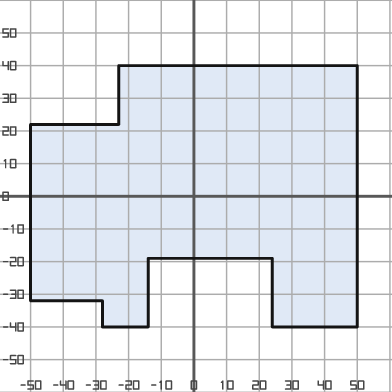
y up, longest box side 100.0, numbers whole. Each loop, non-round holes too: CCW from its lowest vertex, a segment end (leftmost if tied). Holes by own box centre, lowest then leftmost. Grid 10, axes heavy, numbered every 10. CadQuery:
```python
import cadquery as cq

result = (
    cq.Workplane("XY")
    .moveTo(-28.0, -40.0)
    .lineTo(-14.0, -40.0)
    .lineTo(-14.0, -19.0)
    .lineTo(24.0, -19.0)
    .lineTo(24.0, -40.0)
    .lineTo(50.0, -40.0)
    .lineTo(50.0, 40.0)
    .lineTo(-23.0, 40.0)
    .lineTo(-23.0, 22.0)
    .lineTo(-50.0, 22.0)
    .lineTo(-50.0, -32.0)
    .lineTo(-28.0, -32.0)
    .close()
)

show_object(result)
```